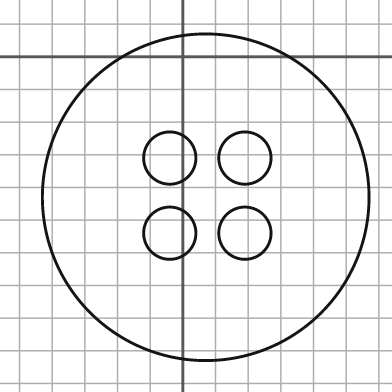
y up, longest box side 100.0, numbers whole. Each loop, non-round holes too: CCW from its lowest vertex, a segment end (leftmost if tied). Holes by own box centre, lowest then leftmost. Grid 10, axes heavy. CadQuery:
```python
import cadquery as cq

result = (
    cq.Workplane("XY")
    .moveTo(7.0, -43.0)
    .circle(50.0)
    .moveTo(-4.0, -54.0)
    .circle(8.0)
    .moveTo(19.0, -54.0)
    .circle(8.0)
    .moveTo(-4.0, -31.0)
    .circle(8.0)
    .moveTo(19.0, -31.0)
    .circle(8.0)
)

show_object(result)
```